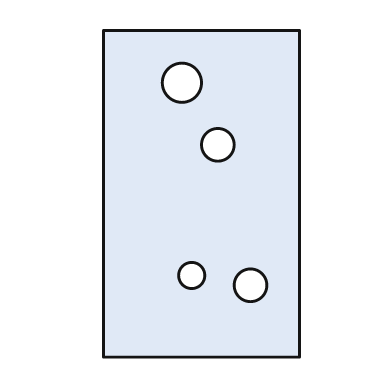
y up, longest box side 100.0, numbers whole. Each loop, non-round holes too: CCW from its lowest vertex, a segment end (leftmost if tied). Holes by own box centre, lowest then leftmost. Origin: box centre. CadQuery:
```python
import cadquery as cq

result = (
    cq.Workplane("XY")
    .moveTo(-30.0, -50.0)
    .lineTo(30.0, -50.0)
    .lineTo(30.0, 50.0)
    .lineTo(-30.0, 50.0)
    .close()
    .moveTo(15.0, -28.0)
    .circle(5.0)
    .moveTo(-3.0, -25.0)
    .circle(4.0)
    .moveTo(5.0, 15.0)
    .circle(5.0)
    .moveTo(-6.0, 34.0)
    .circle(6.0)
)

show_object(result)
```